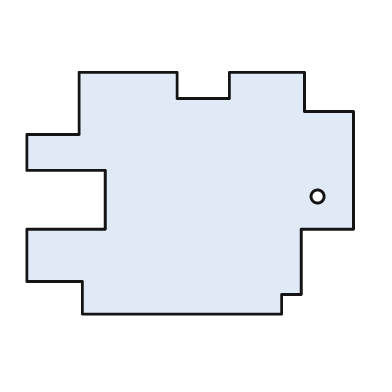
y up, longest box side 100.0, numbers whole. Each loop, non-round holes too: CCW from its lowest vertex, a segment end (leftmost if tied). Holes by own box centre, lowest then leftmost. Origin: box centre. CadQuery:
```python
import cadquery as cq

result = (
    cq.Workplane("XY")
    .moveTo(-33.0, -37.0)
    .lineTo(28.0, -37.0)
    .lineTo(28.0, -31.0)
    .lineTo(34.0, -31.0)
    .lineTo(34.0, -11.0)
    .lineTo(50.0, -11.0)
    .lineTo(50.0, 25.0)
    .lineTo(35.0, 25.0)
    .lineTo(35.0, 37.0)
    .lineTo(12.0, 37.0)
    .lineTo(12.0, 29.0)
    .lineTo(-4.0, 29.0)
    .lineTo(-4.0, 37.0)
    .lineTo(-34.0, 37.0)
    .lineTo(-34.0, 18.0)
    .lineTo(-50.0, 18.0)
    .lineTo(-50.0, 7.0)
    .lineTo(-26.0, 7.0)
    .lineTo(-26.0, -11.0)
    .lineTo(-50.0, -11.0)
    .lineTo(-50.0, -27.0)
    .lineTo(-33.0, -27.0)
    .close()
    .moveTo(39.0, -1.0)
    .circle(2.0)
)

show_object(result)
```